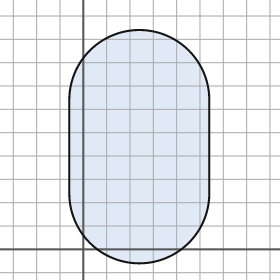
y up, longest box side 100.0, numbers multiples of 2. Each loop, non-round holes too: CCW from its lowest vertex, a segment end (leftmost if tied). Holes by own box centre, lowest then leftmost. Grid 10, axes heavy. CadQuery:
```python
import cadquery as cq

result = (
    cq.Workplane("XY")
    .moveTo(-6.0, 24.0)
    .threePointArc((24.0, -6.0), (54.0, 24.0))
    .lineTo(54.0, 64.0)
    .threePointArc((24.0, 94.0), (-6.0, 64.0))
    .close()
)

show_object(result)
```